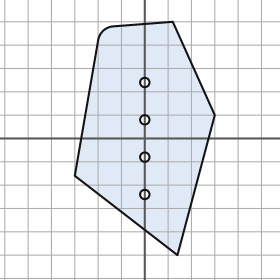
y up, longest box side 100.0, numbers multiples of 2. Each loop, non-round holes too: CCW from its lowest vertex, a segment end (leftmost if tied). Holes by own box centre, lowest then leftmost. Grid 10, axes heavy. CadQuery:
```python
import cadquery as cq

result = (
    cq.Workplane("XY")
    .moveTo(14.0, -50.0)
    .lineTo(30.0, 10.0)
    .lineTo(12.0, 50.0)
    .lineTo(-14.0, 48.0)
    .threePointArc((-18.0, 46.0), (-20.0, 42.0))
    .lineTo(-30.0, -16.0)
    .close()
    .moveTo(0.0, -24.0)
    .circle(2.0)
    .moveTo(0.0, -8.0)
    .circle(2.0)
    .moveTo(0.0, 8.0)
    .circle(2.0)
    .moveTo(0.0, 24.0)
    .circle(2.0)
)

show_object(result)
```